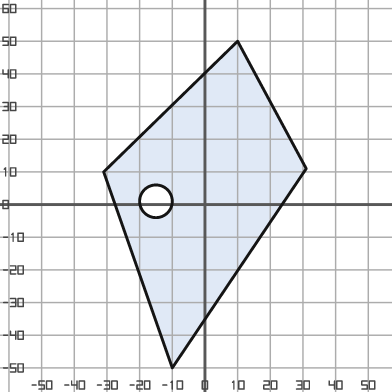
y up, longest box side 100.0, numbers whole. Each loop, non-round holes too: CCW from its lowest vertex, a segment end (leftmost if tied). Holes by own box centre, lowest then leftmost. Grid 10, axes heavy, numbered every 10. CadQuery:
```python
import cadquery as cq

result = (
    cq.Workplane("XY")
    .moveTo(-10.0, -50.0)
    .lineTo(31.0, 11.0)
    .lineTo(10.0, 50.0)
    .lineTo(-31.0, 10.0)
    .close()
    .moveTo(-15.0, 1.0)
    .circle(5.0)
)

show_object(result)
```